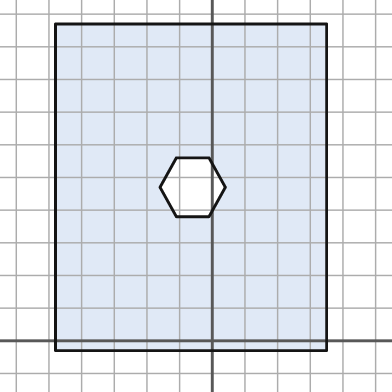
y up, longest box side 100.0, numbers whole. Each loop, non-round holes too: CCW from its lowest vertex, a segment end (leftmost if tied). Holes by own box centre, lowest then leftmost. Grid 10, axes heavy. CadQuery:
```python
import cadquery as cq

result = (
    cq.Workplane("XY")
    .moveTo(-48.0, -3.0)
    .lineTo(35.0, -3.0)
    .lineTo(35.0, 97.0)
    .lineTo(-48.0, 97.0)
    .close()
    .moveTo(-11.0, 38.0)
    .lineTo(-1.0, 38.0)
    .lineTo(4.0, 47.0)
    .lineTo(-1.0, 56.0)
    .lineTo(-11.0, 56.0)
    .lineTo(-16.0, 47.0)
    .close()
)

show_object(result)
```